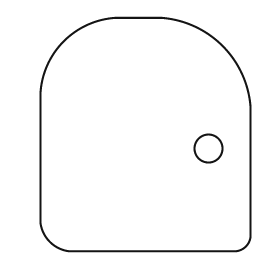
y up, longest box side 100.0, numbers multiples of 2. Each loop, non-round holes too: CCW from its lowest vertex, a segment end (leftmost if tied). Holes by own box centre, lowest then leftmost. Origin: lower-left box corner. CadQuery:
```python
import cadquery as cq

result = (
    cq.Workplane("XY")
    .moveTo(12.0, 0.0)
    .lineTo(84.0, 0.0)
    .threePointArc((88.0, 2.0), (90.0, 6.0))
    .lineTo(90.0, 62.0)
    .threePointArc((78.0, 88.0), (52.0, 100.0))
    .lineTo(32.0, 100.0)
    .threePointArc((10.0, 90.0), (0.0, 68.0))
    .lineTo(0.0, 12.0)
    .threePointArc((4.0, 4.0), (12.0, 0.0))
    .close()
    .moveTo(72.0, 44.0)
    .circle(6.0)
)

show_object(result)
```